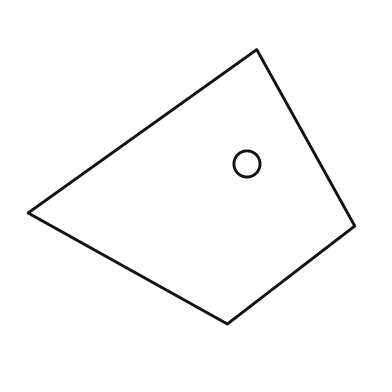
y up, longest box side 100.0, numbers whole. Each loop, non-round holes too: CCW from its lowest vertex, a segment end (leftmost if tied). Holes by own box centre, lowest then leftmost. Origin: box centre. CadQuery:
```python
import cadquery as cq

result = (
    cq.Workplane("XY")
    .moveTo(11.0, -42.0)
    .lineTo(50.0, -12.0)
    .lineTo(20.0, 42.0)
    .lineTo(-50.0, -8.0)
    .close()
    .moveTo(17.0, 7.0)
    .circle(4.0)
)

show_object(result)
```